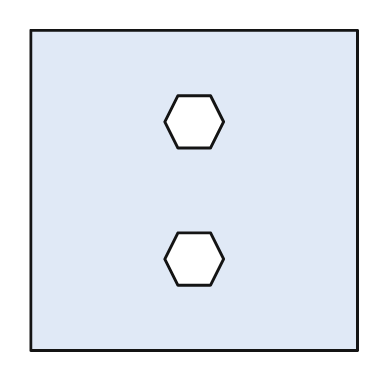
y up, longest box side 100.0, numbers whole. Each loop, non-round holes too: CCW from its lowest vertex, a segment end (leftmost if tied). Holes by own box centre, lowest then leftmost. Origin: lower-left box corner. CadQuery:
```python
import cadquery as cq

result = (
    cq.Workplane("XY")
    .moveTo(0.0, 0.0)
    .lineTo(100.0, 0.0)
    .lineTo(100.0, 98.0)
    .lineTo(0.0, 98.0)
    .close()
    .moveTo(45.0, 20.0)
    .lineTo(55.0, 20.0)
    .lineTo(59.0, 28.0)
    .lineTo(55.0, 36.0)
    .lineTo(45.0, 36.0)
    .lineTo(41.0, 28.0)
    .close()
    .moveTo(45.0, 62.0)
    .lineTo(55.0, 62.0)
    .lineTo(59.0, 70.0)
    .lineTo(55.0, 78.0)
    .lineTo(45.0, 78.0)
    .lineTo(41.0, 70.0)
    .close()
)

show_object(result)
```